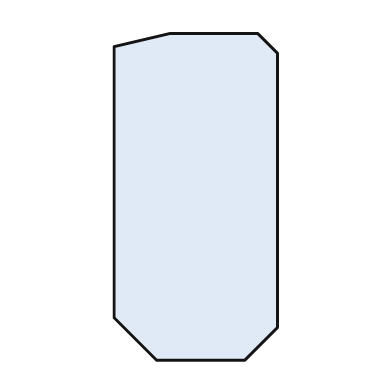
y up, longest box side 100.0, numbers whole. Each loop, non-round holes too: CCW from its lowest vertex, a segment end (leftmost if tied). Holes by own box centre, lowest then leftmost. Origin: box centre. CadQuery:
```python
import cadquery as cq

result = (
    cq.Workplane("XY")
    .moveTo(-12.0, -50.0)
    .lineTo(15.0, -50.0)
    .lineTo(25.0, -40.0)
    .lineTo(25.0, 44.0)
    .lineTo(19.0, 50.0)
    .lineTo(-8.0, 50.0)
    .lineTo(-25.0, 46.0)
    .lineTo(-25.0, -37.0)
    .close()
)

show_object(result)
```